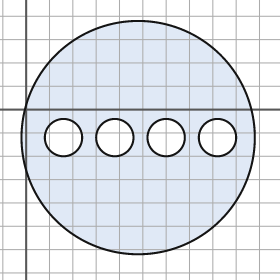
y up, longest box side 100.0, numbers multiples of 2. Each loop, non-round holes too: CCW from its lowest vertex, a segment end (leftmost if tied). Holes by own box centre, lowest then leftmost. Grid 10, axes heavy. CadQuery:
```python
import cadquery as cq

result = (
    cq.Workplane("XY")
    .moveTo(48.0, -12.0)
    .circle(50.0)
    .moveTo(16.0, -12.0)
    .circle(8.0)
    .moveTo(38.0, -12.0)
    .circle(8.0)
    .moveTo(60.0, -12.0)
    .circle(8.0)
    .moveTo(82.0, -12.0)
    .circle(8.0)
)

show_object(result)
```